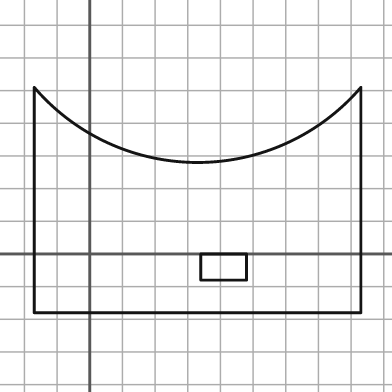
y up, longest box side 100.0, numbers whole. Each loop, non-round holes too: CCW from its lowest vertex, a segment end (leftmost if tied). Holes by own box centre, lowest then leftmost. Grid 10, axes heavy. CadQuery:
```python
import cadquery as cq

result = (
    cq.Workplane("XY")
    .moveTo(-17.0, -18.0)
    .lineTo(83.0, -18.0)
    .lineTo(83.0, 51.0)
    .threePointArc((33.0, 28.0), (-17.0, 51.0))
    .close()
    .moveTo(34.0, -8.0)
    .lineTo(48.0, -8.0)
    .lineTo(48.0, 0.0)
    .lineTo(34.0, 0.0)
    .close()
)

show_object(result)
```